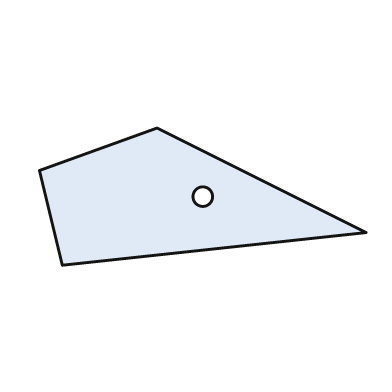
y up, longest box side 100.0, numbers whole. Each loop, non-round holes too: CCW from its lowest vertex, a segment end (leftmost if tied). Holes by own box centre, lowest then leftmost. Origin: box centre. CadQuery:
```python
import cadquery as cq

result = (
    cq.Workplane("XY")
    .moveTo(-43.0, -21.0)
    .lineTo(50.0, -11.0)
    .lineTo(-14.0, 21.0)
    .lineTo(-50.0, 8.0)
    .close()
    .moveTo(0.0, 0.0)
    .circle(3.0)
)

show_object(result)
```